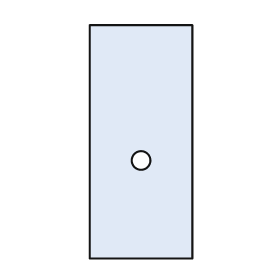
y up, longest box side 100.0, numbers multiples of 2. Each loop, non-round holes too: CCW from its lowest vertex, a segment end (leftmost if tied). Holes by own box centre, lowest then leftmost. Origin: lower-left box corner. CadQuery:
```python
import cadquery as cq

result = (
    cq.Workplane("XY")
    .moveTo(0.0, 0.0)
    .lineTo(44.0, 0.0)
    .lineTo(44.0, 100.0)
    .lineTo(0.0, 100.0)
    .close()
    .moveTo(22.0, 42.0)
    .circle(4.0)
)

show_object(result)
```